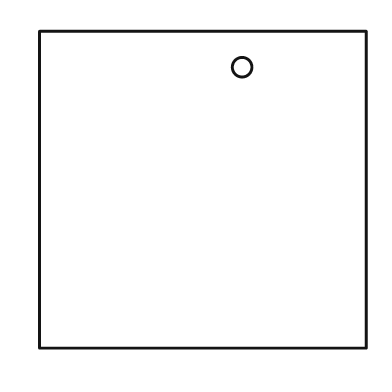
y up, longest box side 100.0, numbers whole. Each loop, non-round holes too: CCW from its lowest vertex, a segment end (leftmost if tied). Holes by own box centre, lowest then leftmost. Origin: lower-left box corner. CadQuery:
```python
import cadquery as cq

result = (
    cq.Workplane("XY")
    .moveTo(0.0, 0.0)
    .lineTo(100.0, 0.0)
    .lineTo(100.0, 97.0)
    .lineTo(0.0, 97.0)
    .close()
    .moveTo(62.0, 86.0)
    .circle(3.0)
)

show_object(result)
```